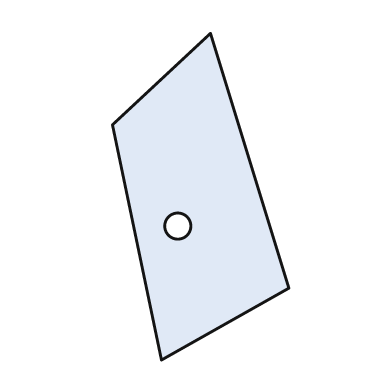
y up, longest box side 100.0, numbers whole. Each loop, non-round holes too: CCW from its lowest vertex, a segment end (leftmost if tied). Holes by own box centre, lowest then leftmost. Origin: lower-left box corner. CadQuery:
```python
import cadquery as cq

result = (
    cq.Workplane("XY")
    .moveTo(15.0, 0.0)
    .lineTo(54.0, 22.0)
    .lineTo(30.0, 100.0)
    .lineTo(0.0, 72.0)
    .close()
    .moveTo(20.0, 41.0)
    .circle(4.0)
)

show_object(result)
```